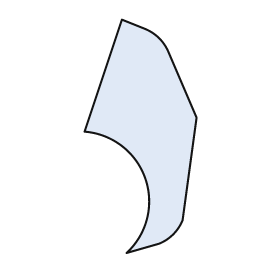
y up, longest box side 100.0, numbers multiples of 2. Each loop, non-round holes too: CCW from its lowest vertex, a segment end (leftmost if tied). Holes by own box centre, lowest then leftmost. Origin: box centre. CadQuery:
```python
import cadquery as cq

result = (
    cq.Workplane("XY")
    .moveTo(-6.0, -50.0)
    .lineTo(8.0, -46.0)
    .threePointArc((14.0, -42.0), (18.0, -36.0))
    .lineTo(24.0, 8.0)
    .lineTo(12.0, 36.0)
    .threePointArc((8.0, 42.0), (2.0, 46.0))
    .lineTo(-8.0, 50.0)
    .lineTo(-24.0, 2.0)
    .threePointArc((2.0, -18.0), (-6.0, -50.0))
    .close()
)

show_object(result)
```